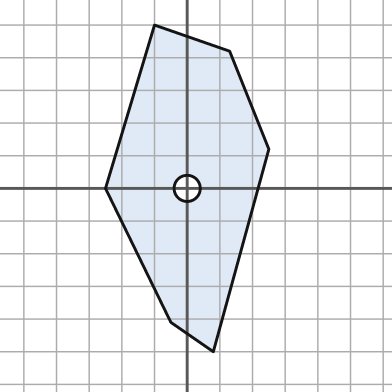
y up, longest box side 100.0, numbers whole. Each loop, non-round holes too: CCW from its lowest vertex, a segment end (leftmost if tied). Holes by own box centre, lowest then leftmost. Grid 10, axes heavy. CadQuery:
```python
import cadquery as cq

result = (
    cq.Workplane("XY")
    .moveTo(8.0, -50.0)
    .lineTo(25.0, 12.0)
    .lineTo(13.0, 42.0)
    .lineTo(-10.0, 50.0)
    .lineTo(-25.0, 0.0)
    .lineTo(-5.0, -41.0)
    .close()
    .moveTo(0.0, 0.0)
    .circle(4.0)
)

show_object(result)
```